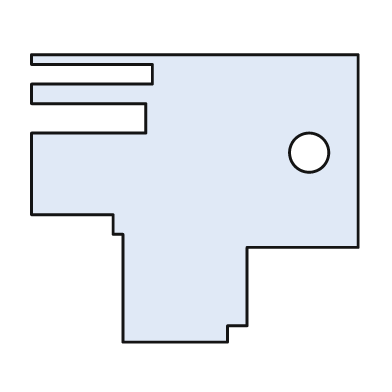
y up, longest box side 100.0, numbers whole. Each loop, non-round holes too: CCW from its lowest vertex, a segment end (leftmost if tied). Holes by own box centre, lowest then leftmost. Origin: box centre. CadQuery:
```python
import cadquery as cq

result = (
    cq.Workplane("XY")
    .moveTo(-22.0, -44.0)
    .lineTo(10.0, -44.0)
    .lineTo(10.0, -39.0)
    .lineTo(16.0, -39.0)
    .lineTo(16.0, -15.0)
    .lineTo(50.0, -15.0)
    .lineTo(50.0, 44.0)
    .lineTo(-50.0, 44.0)
    .lineTo(-50.0, 41.0)
    .lineTo(-13.0, 41.0)
    .lineTo(-13.0, 35.0)
    .lineTo(-50.0, 35.0)
    .lineTo(-50.0, 29.0)
    .lineTo(-15.0, 29.0)
    .lineTo(-15.0, 20.0)
    .lineTo(-50.0, 20.0)
    .lineTo(-50.0, -5.0)
    .lineTo(-25.0, -5.0)
    .lineTo(-25.0, -11.0)
    .lineTo(-22.0, -11.0)
    .close()
    .moveTo(35.0, 14.0)
    .circle(6.0)
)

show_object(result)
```